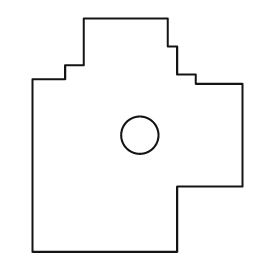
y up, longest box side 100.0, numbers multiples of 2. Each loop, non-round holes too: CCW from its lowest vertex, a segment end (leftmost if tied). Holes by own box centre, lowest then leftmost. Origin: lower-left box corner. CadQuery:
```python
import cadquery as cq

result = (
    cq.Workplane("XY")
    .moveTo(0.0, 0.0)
    .lineTo(62.0, 0.0)
    .lineTo(62.0, 28.0)
    .lineTo(90.0, 28.0)
    .lineTo(90.0, 72.0)
    .lineTo(70.0, 72.0)
    .lineTo(70.0, 76.0)
    .lineTo(62.0, 76.0)
    .lineTo(62.0, 88.0)
    .lineTo(58.0, 88.0)
    .lineTo(58.0, 100.0)
    .lineTo(22.0, 100.0)
    .lineTo(22.0, 80.0)
    .lineTo(14.0, 80.0)
    .lineTo(14.0, 74.0)
    .lineTo(0.0, 74.0)
    .close()
    .moveTo(46.0, 50.0)
    .circle(8.0)
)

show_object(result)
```